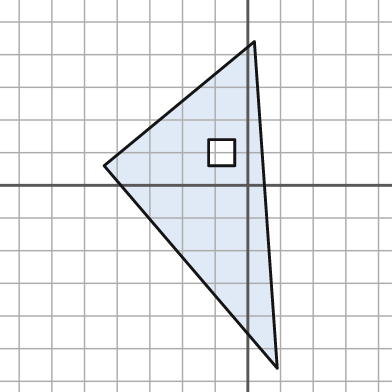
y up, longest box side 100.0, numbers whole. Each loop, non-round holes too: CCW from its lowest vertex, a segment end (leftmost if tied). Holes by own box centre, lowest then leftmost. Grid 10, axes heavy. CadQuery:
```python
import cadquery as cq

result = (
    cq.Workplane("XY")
    .moveTo(9.0, -56.0)
    .lineTo(2.0, 44.0)
    .lineTo(-44.0, 6.0)
    .close()
    .moveTo(-12.0, 6.0)
    .lineTo(-4.0, 6.0)
    .lineTo(-4.0, 14.0)
    .lineTo(-12.0, 14.0)
    .close()
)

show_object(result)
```